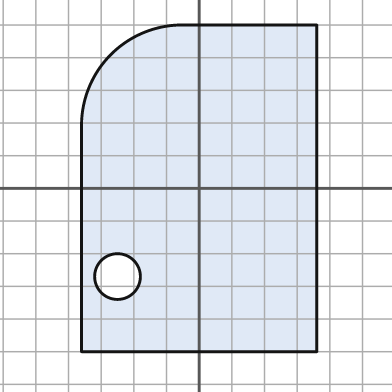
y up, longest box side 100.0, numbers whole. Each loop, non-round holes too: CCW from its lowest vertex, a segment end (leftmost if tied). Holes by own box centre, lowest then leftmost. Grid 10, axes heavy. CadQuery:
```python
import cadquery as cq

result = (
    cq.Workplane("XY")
    .moveTo(-36.0, -50.0)
    .lineTo(36.0, -50.0)
    .lineTo(36.0, 50.0)
    .lineTo(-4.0, 50.0)
    .threePointArc((-27.0, 41.0), (-36.0, 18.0))
    .close()
    .moveTo(-25.0, -27.0)
    .circle(7.0)
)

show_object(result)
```